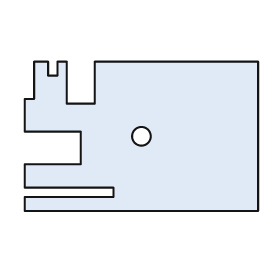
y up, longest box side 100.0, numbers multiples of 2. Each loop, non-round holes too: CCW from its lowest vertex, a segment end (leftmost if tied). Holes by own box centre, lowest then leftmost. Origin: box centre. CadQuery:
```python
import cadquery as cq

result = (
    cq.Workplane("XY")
    .moveTo(-50.0, -32.0)
    .lineTo(50.0, -32.0)
    .lineTo(50.0, 32.0)
    .lineTo(-20.0, 32.0)
    .lineTo(-20.0, 14.0)
    .lineTo(-32.0, 14.0)
    .lineTo(-32.0, 32.0)
    .lineTo(-36.0, 32.0)
    .lineTo(-36.0, 26.0)
    .lineTo(-40.0, 26.0)
    .lineTo(-40.0, 32.0)
    .lineTo(-46.0, 32.0)
    .lineTo(-46.0, 16.0)
    .lineTo(-50.0, 16.0)
    .lineTo(-50.0, 2.0)
    .lineTo(-26.0, 2.0)
    .lineTo(-26.0, -12.0)
    .lineTo(-50.0, -12.0)
    .lineTo(-50.0, -22.0)
    .lineTo(-12.0, -22.0)
    .lineTo(-12.0, -26.0)
    .lineTo(-50.0, -26.0)
    .close()
    .moveTo(0.0, 0.0)
    .circle(4.0)
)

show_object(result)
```